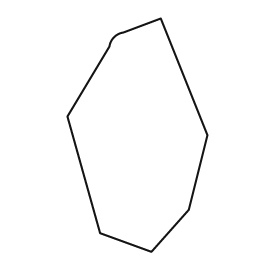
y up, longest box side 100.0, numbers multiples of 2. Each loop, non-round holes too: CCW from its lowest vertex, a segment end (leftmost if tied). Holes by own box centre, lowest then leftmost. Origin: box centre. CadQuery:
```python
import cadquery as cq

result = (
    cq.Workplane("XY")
    .moveTo(6.0, -50.0)
    .lineTo(22.0, -32.0)
    .lineTo(30.0, 0.0)
    .lineTo(10.0, 50.0)
    .lineTo(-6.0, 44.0)
    .threePointArc((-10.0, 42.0), (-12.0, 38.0))
    .lineTo(-30.0, 8.0)
    .lineTo(-16.0, -42.0)
    .close()
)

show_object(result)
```